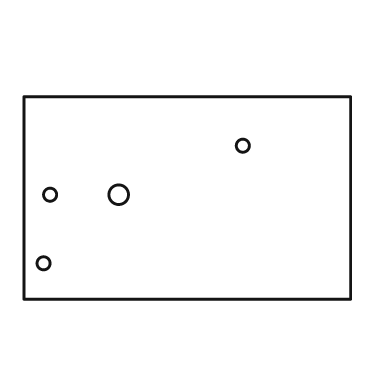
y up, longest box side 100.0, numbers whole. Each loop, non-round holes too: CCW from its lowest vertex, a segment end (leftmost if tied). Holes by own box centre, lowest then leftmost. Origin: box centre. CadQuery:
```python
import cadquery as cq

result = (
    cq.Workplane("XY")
    .moveTo(-50.0, -31.0)
    .lineTo(50.0, -31.0)
    .lineTo(50.0, 31.0)
    .lineTo(-50.0, 31.0)
    .close()
    .moveTo(-44.0, -20.0)
    .circle(2.0)
    .moveTo(-42.0, 1.0)
    .circle(2.0)
    .moveTo(-21.0, 1.0)
    .circle(3.0)
    .moveTo(17.0, 16.0)
    .circle(2.0)
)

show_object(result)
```